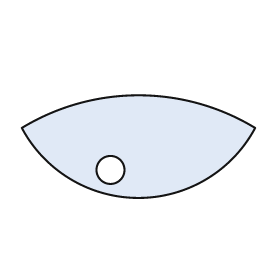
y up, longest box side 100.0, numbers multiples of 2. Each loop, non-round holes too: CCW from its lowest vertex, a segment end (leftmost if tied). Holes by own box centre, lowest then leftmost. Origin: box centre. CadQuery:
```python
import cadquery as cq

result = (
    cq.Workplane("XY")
    .moveTo(-50.0, 8.0)
    .threePointArc((0.0, -22.0), (50.0, 8.0))
    .threePointArc((0.0, 22.0), (-50.0, 8.0))
    .close()
    .moveTo(-12.0, -10.0)
    .circle(6.0)
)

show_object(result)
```